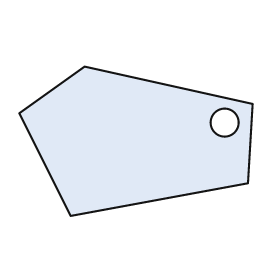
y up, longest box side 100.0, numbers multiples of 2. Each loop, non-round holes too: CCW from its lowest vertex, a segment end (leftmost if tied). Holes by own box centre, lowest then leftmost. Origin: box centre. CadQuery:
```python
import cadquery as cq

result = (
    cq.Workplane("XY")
    .moveTo(-28.0, -32.0)
    .lineTo(48.0, -18.0)
    .lineTo(50.0, 16.0)
    .lineTo(-22.0, 32.0)
    .lineTo(-50.0, 12.0)
    .close()
    .moveTo(38.0, 8.0)
    .circle(6.0)
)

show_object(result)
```